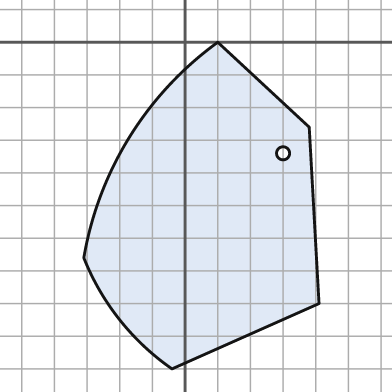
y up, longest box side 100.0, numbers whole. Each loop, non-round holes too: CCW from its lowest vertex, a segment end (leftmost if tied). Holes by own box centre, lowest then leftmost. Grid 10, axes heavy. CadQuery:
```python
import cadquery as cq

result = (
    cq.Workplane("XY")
    .moveTo(-4.0, -100.0)
    .lineTo(41.0, -80.0)
    .lineTo(38.0, -26.0)
    .lineTo(10.0, 0.0)
    .threePointArc((-17.0, -29.0), (-31.0, -66.0))
    .threePointArc((-20.0, -85.0), (-4.0, -100.0))
    .close()
    .moveTo(30.0, -34.0)
    .circle(2.0)
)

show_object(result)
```